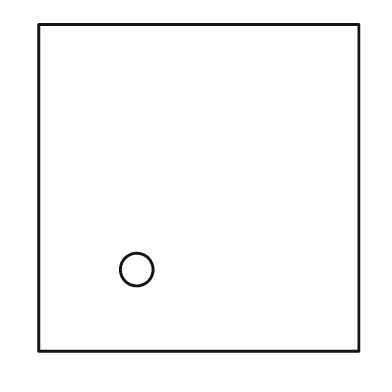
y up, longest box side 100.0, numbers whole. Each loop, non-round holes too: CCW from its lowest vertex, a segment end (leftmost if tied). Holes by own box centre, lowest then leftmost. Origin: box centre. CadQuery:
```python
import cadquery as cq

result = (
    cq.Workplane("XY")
    .moveTo(-49.0, -50.0)
    .lineTo(49.0, -50.0)
    .lineTo(49.0, 50.0)
    .lineTo(-49.0, 50.0)
    .close()
    .moveTo(-19.0, -25.0)
    .circle(5.0)
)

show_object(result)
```